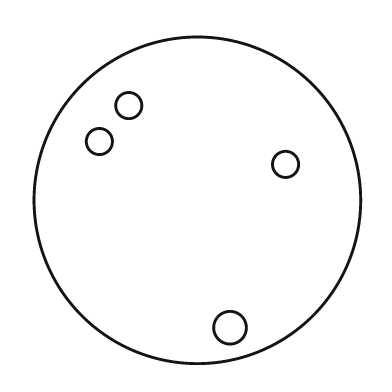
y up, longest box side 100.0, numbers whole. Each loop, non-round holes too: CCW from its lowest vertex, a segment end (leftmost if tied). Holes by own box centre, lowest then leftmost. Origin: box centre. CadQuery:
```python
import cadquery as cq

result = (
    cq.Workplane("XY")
    .moveTo(0.0, 0.0)
    .circle(50.0)
    .moveTo(10.0, -39.0)
    .circle(5.0)
    .moveTo(27.0, 11.0)
    .circle(4.0)
    .moveTo(-30.0, 18.0)
    .circle(4.0)
    .moveTo(-21.0, 29.0)
    .circle(4.0)
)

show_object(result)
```